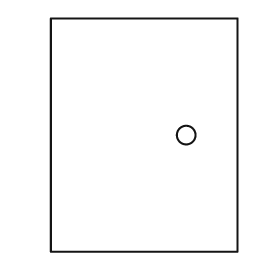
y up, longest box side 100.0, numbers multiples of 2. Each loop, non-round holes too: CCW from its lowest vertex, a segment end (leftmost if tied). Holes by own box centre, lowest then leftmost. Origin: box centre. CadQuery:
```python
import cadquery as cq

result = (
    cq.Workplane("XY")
    .moveTo(-40.0, -50.0)
    .lineTo(40.0, -50.0)
    .lineTo(40.0, 50.0)
    .lineTo(-40.0, 50.0)
    .close()
    .moveTo(18.0, 0.0)
    .circle(4.0)
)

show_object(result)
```